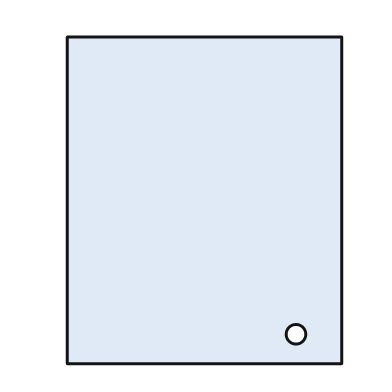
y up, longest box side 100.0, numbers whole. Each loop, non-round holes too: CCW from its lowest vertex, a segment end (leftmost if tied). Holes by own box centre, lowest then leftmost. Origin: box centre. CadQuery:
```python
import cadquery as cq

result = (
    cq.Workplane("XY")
    .moveTo(-42.0, -50.0)
    .lineTo(42.0, -50.0)
    .lineTo(42.0, 50.0)
    .lineTo(-42.0, 50.0)
    .close()
    .moveTo(28.0, -41.0)
    .circle(3.0)
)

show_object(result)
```